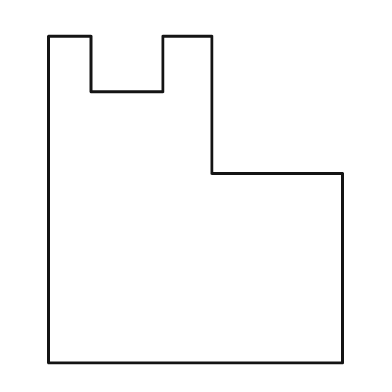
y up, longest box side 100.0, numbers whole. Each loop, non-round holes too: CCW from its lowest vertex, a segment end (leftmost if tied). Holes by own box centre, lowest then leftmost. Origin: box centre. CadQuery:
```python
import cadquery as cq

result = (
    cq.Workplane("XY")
    .moveTo(-45.0, -50.0)
    .lineTo(45.0, -50.0)
    .lineTo(45.0, 8.0)
    .lineTo(5.0, 8.0)
    .lineTo(5.0, 50.0)
    .lineTo(-10.0, 50.0)
    .lineTo(-10.0, 33.0)
    .lineTo(-32.0, 33.0)
    .lineTo(-32.0, 50.0)
    .lineTo(-45.0, 50.0)
    .close()
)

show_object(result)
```